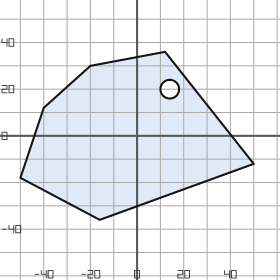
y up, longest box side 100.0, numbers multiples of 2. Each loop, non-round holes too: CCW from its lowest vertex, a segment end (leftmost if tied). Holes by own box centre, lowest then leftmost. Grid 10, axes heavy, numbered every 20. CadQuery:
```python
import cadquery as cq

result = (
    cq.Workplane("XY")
    .moveTo(-16.0, -36.0)
    .lineTo(50.0, -12.0)
    .lineTo(12.0, 36.0)
    .lineTo(-20.0, 30.0)
    .lineTo(-40.0, 12.0)
    .lineTo(-50.0, -18.0)
    .close()
    .moveTo(14.0, 20.0)
    .circle(4.0)
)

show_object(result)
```